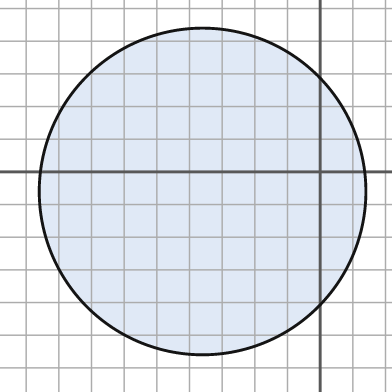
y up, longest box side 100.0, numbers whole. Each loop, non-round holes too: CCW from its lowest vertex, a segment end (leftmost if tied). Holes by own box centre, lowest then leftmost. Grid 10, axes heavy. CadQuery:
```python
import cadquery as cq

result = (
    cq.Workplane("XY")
    .moveTo(-36.0, -6.0)
    .circle(50.0)
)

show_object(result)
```